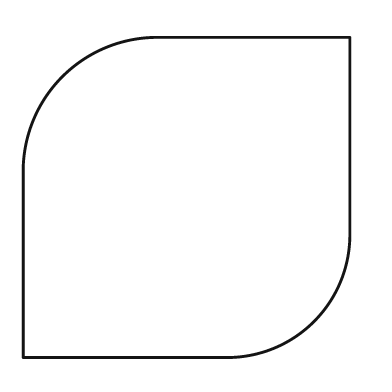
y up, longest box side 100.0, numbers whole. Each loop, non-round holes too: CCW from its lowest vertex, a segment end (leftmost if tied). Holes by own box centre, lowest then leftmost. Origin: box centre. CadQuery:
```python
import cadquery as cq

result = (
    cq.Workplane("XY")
    .moveTo(-50.0, -49.0)
    .lineTo(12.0, -49.0)
    .threePointArc((39.0, -38.0), (50.0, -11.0))
    .lineTo(50.0, 49.0)
    .lineTo(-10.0, 49.0)
    .threePointArc((-38.0, 37.0), (-50.0, 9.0))
    .close()
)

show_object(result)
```